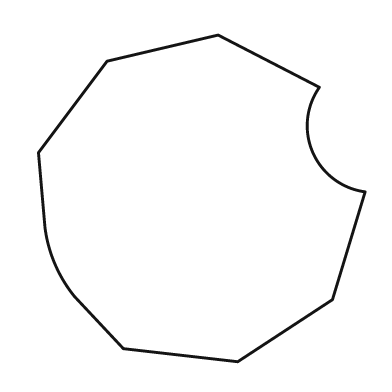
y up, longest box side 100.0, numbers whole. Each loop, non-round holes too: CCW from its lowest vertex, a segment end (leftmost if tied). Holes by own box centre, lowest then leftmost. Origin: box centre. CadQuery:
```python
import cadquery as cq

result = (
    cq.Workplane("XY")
    .moveTo(11.0, -50.0)
    .lineTo(40.0, -31.0)
    .lineTo(50.0, 2.0)
    .threePointArc((34.0, 14.0), (36.0, 34.0))
    .lineTo(5.0, 50.0)
    .lineTo(-29.0, 42.0)
    .lineTo(-50.0, 14.0)
    .lineTo(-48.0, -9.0)
    .threePointArc((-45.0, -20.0), (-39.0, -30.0))
    .lineTo(-24.0, -46.0)
    .close()
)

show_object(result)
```